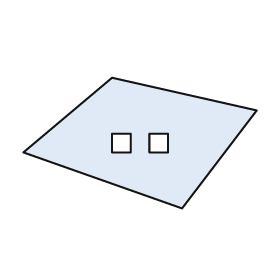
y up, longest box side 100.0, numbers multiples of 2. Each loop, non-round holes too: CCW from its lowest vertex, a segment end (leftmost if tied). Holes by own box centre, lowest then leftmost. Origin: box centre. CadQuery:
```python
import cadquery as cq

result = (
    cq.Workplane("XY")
    .moveTo(18.0, -28.0)
    .lineTo(50.0, 14.0)
    .lineTo(-12.0, 28.0)
    .lineTo(-50.0, -4.0)
    .close()
    .moveTo(-12.0, -4.0)
    .lineTo(-4.0, -4.0)
    .lineTo(-4.0, 4.0)
    .lineTo(-12.0, 4.0)
    .close()
    .moveTo(4.0, -4.0)
    .lineTo(12.0, -4.0)
    .lineTo(12.0, 4.0)
    .lineTo(4.0, 4.0)
    .close()
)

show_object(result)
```